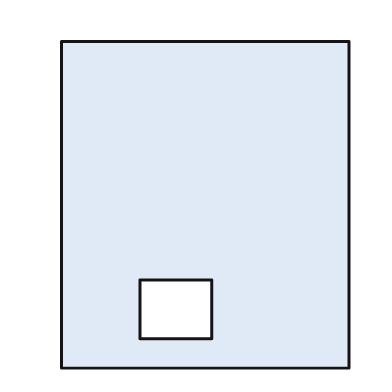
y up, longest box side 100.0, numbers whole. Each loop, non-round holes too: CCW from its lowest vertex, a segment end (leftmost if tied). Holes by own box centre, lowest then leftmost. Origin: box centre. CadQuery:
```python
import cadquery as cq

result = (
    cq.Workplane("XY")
    .moveTo(-44.0, -50.0)
    .lineTo(44.0, -50.0)
    .lineTo(44.0, 50.0)
    .lineTo(-44.0, 50.0)
    .close()
    .moveTo(-20.0, -41.0)
    .lineTo(2.0, -41.0)
    .lineTo(2.0, -23.0)
    .lineTo(-20.0, -23.0)
    .close()
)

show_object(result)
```